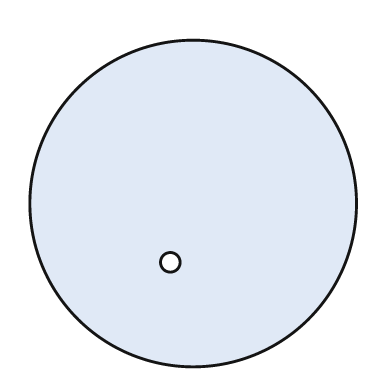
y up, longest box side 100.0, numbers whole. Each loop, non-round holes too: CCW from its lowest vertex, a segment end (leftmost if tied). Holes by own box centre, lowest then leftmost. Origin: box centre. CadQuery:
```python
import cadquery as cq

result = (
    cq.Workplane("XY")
    .moveTo(0.0, 0.0)
    .circle(50.0)
    .moveTo(-7.0, -18.0)
    .circle(3.0)
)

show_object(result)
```